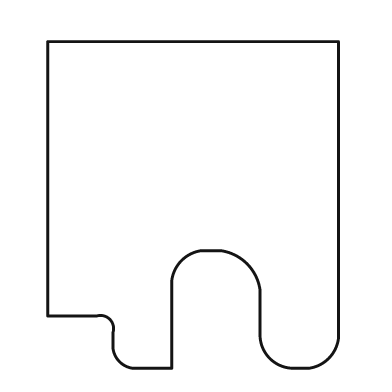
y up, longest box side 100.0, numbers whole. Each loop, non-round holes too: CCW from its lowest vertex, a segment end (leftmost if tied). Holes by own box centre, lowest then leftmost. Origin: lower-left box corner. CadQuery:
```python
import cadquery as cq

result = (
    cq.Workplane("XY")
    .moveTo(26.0, 0.0)
    .lineTo(38.0, 0.0)
    .lineTo(38.0, 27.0)
    .threePointArc((41.0, 33.0), (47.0, 36.0))
    .lineTo(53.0, 36.0)
    .threePointArc((61.0, 32.0), (65.0, 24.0))
    .lineTo(65.0, 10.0)
    .threePointArc((68.0, 3.0), (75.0, 0.0))
    .lineTo(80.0, 0.0)
    .threePointArc((86.0, 3.0), (89.0, 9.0))
    .lineTo(89.0, 100.0)
    .lineTo(0.0, 100.0)
    .lineTo(0.0, 16.0)
    .lineTo(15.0, 16.0)
    .threePointArc((19.0, 15.0), (20.0, 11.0))
    .lineTo(20.0, 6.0)
    .threePointArc((22.0, 2.0), (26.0, 0.0))
    .close()
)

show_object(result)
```